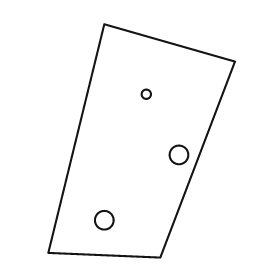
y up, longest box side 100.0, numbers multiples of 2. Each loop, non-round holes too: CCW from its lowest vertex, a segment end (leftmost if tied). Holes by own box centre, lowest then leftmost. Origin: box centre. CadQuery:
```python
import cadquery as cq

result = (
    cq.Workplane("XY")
    .moveTo(8.0, -50.0)
    .lineTo(40.0, 34.0)
    .lineTo(-16.0, 50.0)
    .lineTo(-40.0, -48.0)
    .close()
    .moveTo(-16.0, -34.0)
    .circle(4.0)
    .moveTo(16.0, -6.0)
    .circle(4.0)
    .moveTo(2.0, 20.0)
    .circle(2.0)
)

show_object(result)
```